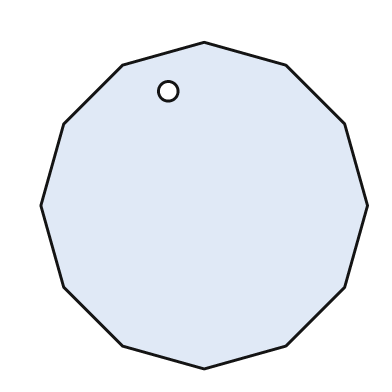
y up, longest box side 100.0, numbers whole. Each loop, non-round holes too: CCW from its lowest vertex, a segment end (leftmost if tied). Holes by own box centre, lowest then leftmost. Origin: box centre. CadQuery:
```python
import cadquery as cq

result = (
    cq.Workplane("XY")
    .moveTo(0.0, -50.0)
    .lineTo(25.0, -43.0)
    .lineTo(43.0, -25.0)
    .lineTo(50.0, 0.0)
    .lineTo(43.0, 25.0)
    .lineTo(25.0, 43.0)
    .lineTo(0.0, 50.0)
    .lineTo(-25.0, 43.0)
    .lineTo(-43.0, 25.0)
    .lineTo(-50.0, 0.0)
    .lineTo(-43.0, -25.0)
    .lineTo(-25.0, -43.0)
    .close()
    .moveTo(-11.0, 35.0)
    .circle(3.0)
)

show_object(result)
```